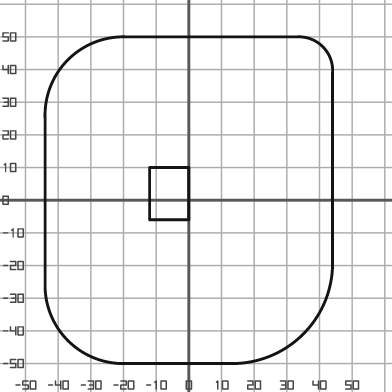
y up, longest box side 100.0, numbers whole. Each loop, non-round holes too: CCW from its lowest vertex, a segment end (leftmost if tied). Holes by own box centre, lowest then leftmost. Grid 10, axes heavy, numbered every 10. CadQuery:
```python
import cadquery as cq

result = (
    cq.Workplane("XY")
    .moveTo(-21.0, -50.0)
    .lineTo(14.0, -50.0)
    .threePointArc((35.0, -41.0), (44.0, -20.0))
    .lineTo(44.0, 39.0)
    .threePointArc((41.0, 47.0), (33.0, 50.0))
    .lineTo(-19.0, 50.0)
    .threePointArc((-37.0, 43.0), (-44.0, 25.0))
    .lineTo(-44.0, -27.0)
    .threePointArc((-37.0, -43.0), (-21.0, -50.0))
    .close()
    .moveTo(-12.0, -6.0)
    .lineTo(0.0, -6.0)
    .lineTo(0.0, 10.0)
    .lineTo(-12.0, 10.0)
    .close()
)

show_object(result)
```